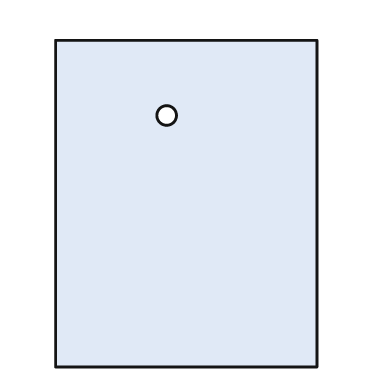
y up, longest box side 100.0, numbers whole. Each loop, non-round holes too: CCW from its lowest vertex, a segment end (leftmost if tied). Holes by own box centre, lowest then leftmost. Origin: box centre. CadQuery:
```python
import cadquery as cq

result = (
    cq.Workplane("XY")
    .moveTo(-40.0, -50.0)
    .lineTo(40.0, -50.0)
    .lineTo(40.0, 50.0)
    .lineTo(-40.0, 50.0)
    .close()
    .moveTo(-6.0, 27.0)
    .circle(3.0)
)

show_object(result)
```